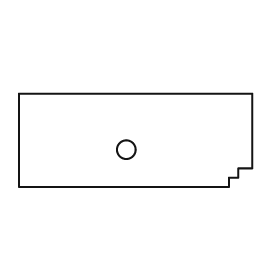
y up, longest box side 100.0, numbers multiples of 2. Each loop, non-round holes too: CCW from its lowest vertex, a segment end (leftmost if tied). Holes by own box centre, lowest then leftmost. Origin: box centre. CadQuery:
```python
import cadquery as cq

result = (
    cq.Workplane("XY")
    .moveTo(-50.0, -20.0)
    .lineTo(40.0, -20.0)
    .lineTo(40.0, -16.0)
    .lineTo(44.0, -16.0)
    .lineTo(44.0, -12.0)
    .lineTo(50.0, -12.0)
    .lineTo(50.0, 20.0)
    .lineTo(-50.0, 20.0)
    .close()
    .moveTo(-4.0, -4.0)
    .circle(4.0)
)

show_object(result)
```